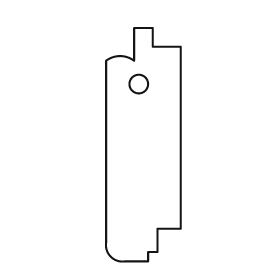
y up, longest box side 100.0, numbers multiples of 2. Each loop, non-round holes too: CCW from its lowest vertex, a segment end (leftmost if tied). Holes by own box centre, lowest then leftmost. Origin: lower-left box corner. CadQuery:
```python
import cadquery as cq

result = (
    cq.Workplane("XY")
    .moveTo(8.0, 0.0)
    .lineTo(18.0, 0.0)
    .lineTo(18.0, 4.0)
    .lineTo(22.0, 4.0)
    .lineTo(22.0, 14.0)
    .lineTo(32.0, 14.0)
    .lineTo(32.0, 92.0)
    .lineTo(20.0, 92.0)
    .lineTo(20.0, 100.0)
    .lineTo(12.0, 100.0)
    .lineTo(12.0, 86.0)
    .threePointArc((6.0, 88.0), (0.0, 86.0))
    .lineTo(0.0, 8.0)
    .threePointArc((2.0, 2.0), (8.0, 0.0))
    .close()
    .moveTo(14.0, 76.0)
    .circle(4.0)
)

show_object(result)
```